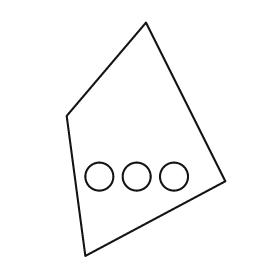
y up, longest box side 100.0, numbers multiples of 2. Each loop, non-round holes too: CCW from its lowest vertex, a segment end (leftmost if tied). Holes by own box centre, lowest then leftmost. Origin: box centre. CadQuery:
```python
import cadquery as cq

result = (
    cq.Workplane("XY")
    .moveTo(-26.0, -50.0)
    .lineTo(34.0, -18.0)
    .lineTo(0.0, 50.0)
    .lineTo(-34.0, 10.0)
    .close()
    .moveTo(-20.0, -16.0)
    .circle(6.0)
    .moveTo(-4.0, -16.0)
    .circle(6.0)
    .moveTo(12.0, -16.0)
    .circle(6.0)
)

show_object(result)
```